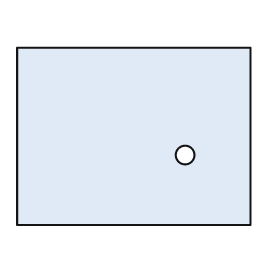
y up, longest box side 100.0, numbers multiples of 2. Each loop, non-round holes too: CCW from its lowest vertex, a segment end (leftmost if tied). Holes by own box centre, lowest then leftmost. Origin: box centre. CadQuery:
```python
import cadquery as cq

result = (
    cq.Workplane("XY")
    .moveTo(-50.0, -38.0)
    .lineTo(50.0, -38.0)
    .lineTo(50.0, 38.0)
    .lineTo(-50.0, 38.0)
    .close()
    .moveTo(22.0, -8.0)
    .circle(4.0)
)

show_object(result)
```